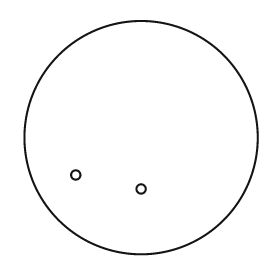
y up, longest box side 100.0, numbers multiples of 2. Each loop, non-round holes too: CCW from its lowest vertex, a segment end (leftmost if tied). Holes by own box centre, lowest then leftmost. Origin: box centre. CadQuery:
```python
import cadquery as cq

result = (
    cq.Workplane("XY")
    .moveTo(0.0, 0.0)
    .circle(50.0)
    .moveTo(0.0, -22.0)
    .circle(2.0)
    .moveTo(-28.0, -16.0)
    .circle(2.0)
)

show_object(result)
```